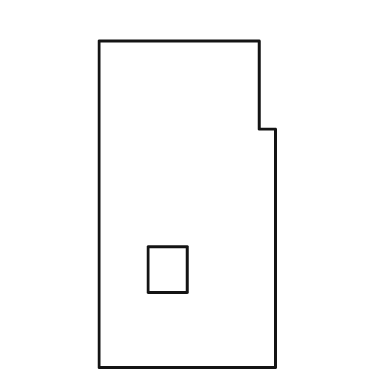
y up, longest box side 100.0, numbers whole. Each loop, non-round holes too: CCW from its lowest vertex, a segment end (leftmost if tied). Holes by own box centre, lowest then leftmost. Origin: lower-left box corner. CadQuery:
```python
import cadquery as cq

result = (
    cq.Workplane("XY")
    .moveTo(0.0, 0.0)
    .lineTo(54.0, 0.0)
    .lineTo(54.0, 73.0)
    .lineTo(49.0, 73.0)
    .lineTo(49.0, 100.0)
    .lineTo(0.0, 100.0)
    .close()
    .moveTo(15.0, 23.0)
    .lineTo(27.0, 23.0)
    .lineTo(27.0, 37.0)
    .lineTo(15.0, 37.0)
    .close()
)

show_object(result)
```